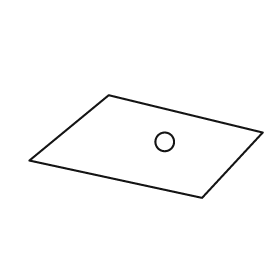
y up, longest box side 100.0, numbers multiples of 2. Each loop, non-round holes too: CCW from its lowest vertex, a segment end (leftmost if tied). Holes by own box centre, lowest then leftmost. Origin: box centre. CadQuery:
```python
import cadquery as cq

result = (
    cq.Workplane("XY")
    .moveTo(24.0, -22.0)
    .lineTo(50.0, 6.0)
    .lineTo(-16.0, 22.0)
    .lineTo(-50.0, -6.0)
    .close()
    .moveTo(8.0, 2.0)
    .circle(4.0)
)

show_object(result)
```